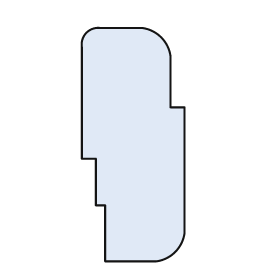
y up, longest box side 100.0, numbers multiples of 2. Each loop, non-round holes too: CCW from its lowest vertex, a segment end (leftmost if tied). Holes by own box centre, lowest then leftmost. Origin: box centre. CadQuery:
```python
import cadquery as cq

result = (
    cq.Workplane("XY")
    .moveTo(-12.0, -50.0)
    .lineTo(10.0, -50.0)
    .threePointArc((18.0, -46.0), (22.0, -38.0))
    .lineTo(22.0, 16.0)
    .lineTo(16.0, 16.0)
    .lineTo(16.0, 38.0)
    .threePointArc((12.0, 46.0), (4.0, 50.0))
    .lineTo(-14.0, 50.0)
    .threePointArc((-20.0, 48.0), (-22.0, 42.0))
    .lineTo(-22.0, -6.0)
    .lineTo(-16.0, -6.0)
    .lineTo(-16.0, -26.0)
    .lineTo(-12.0, -26.0)
    .close()
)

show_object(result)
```